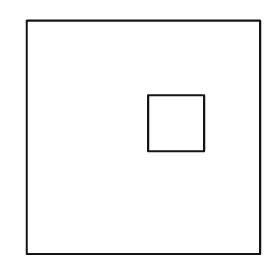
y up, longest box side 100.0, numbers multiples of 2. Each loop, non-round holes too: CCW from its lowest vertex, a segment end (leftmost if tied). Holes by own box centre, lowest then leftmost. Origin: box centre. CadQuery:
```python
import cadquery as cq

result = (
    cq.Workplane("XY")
    .moveTo(-50.0, -50.0)
    .lineTo(50.0, -50.0)
    .lineTo(50.0, 50.0)
    .lineTo(-50.0, 50.0)
    .close()
    .moveTo(2.0, -6.0)
    .lineTo(26.0, -6.0)
    .lineTo(26.0, 18.0)
    .lineTo(2.0, 18.0)
    .close()
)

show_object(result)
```